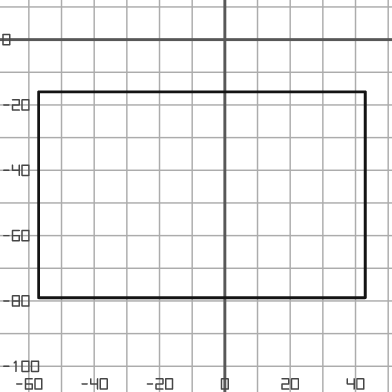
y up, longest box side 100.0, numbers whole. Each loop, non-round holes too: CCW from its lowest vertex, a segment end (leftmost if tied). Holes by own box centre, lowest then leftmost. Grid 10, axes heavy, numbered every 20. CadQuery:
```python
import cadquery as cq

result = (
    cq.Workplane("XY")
    .moveTo(-57.0, -79.0)
    .lineTo(43.0, -79.0)
    .lineTo(43.0, -16.0)
    .lineTo(-57.0, -16.0)
    .close()
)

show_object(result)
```